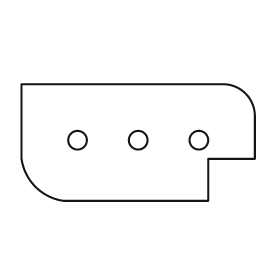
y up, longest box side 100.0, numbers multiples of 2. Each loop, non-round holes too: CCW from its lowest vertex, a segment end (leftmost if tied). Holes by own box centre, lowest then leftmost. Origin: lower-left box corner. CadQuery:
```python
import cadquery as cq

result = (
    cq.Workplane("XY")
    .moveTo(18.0, 0.0)
    .lineTo(80.0, 0.0)
    .lineTo(80.0, 18.0)
    .lineTo(100.0, 18.0)
    .lineTo(100.0, 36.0)
    .threePointArc((96.0, 46.0), (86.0, 50.0))
    .lineTo(0.0, 50.0)
    .lineTo(0.0, 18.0)
    .threePointArc((6.0, 6.0), (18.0, 0.0))
    .close()
    .moveTo(24.0, 26.0)
    .circle(4.0)
    .moveTo(50.0, 26.0)
    .circle(4.0)
    .moveTo(76.0, 26.0)
    .circle(4.0)
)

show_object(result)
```